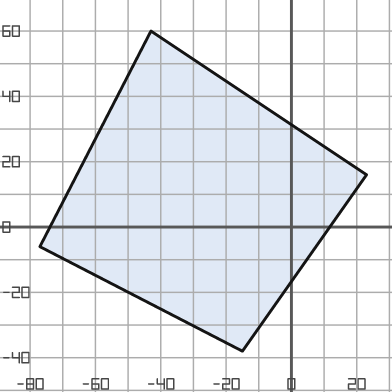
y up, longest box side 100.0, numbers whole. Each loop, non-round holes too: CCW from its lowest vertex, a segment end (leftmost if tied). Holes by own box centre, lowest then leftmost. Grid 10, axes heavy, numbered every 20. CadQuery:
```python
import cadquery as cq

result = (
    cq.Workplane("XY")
    .moveTo(-15.0, -38.0)
    .lineTo(23.0, 16.0)
    .lineTo(-43.0, 60.0)
    .lineTo(-77.0, -6.0)
    .close()
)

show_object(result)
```